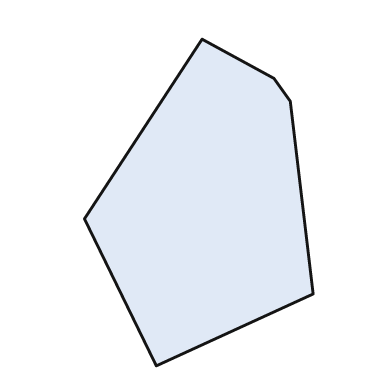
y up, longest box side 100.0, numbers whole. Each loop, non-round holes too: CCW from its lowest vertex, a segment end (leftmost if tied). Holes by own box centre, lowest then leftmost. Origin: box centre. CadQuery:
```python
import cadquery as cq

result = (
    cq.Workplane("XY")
    .moveTo(-13.0, -50.0)
    .lineTo(35.0, -28.0)
    .lineTo(28.0, 31.0)
    .lineTo(23.0, 38.0)
    .lineTo(1.0, 50.0)
    .lineTo(-35.0, -5.0)
    .close()
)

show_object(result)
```